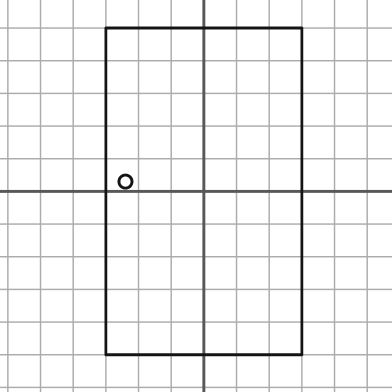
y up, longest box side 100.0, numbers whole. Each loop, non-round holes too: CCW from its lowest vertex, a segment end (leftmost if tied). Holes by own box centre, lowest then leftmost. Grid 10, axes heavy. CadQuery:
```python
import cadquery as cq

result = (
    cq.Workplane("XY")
    .moveTo(-30.0, -50.0)
    .lineTo(30.0, -50.0)
    .lineTo(30.0, 50.0)
    .lineTo(-30.0, 50.0)
    .close()
    .moveTo(-24.0, 3.0)
    .circle(2.0)
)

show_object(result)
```